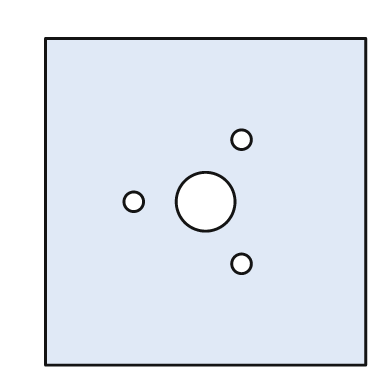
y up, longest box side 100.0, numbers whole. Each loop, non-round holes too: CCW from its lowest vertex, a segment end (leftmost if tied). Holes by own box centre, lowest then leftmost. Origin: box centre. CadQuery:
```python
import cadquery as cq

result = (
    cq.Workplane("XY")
    .moveTo(-49.0, -50.0)
    .lineTo(49.0, -50.0)
    .lineTo(49.0, 50.0)
    .lineTo(-49.0, 50.0)
    .close()
    .moveTo(11.0, -19.0)
    .circle(3.0)
    .moveTo(-22.0, 0.0)
    .circle(3.0)
    .moveTo(0.0, 0.0)
    .circle(9.0)
    .moveTo(11.0, 19.0)
    .circle(3.0)
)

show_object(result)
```